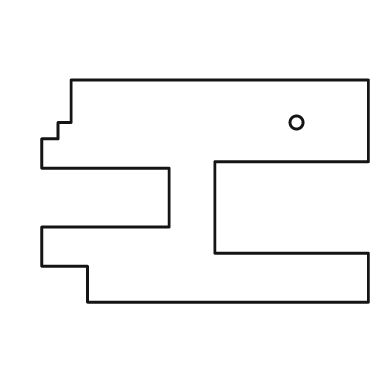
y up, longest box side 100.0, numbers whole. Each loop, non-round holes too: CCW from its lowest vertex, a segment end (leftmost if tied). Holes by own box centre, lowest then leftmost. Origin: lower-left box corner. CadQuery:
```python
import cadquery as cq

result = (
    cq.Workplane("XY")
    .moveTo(14.0, 0.0)
    .lineTo(100.0, 0.0)
    .lineTo(100.0, 15.0)
    .lineTo(53.0, 15.0)
    .lineTo(53.0, 43.0)
    .lineTo(100.0, 43.0)
    .lineTo(100.0, 68.0)
    .lineTo(9.0, 68.0)
    .lineTo(9.0, 55.0)
    .lineTo(5.0, 55.0)
    .lineTo(5.0, 50.0)
    .lineTo(0.0, 50.0)
    .lineTo(0.0, 41.0)
    .lineTo(39.0, 41.0)
    .lineTo(39.0, 23.0)
    .lineTo(0.0, 23.0)
    .lineTo(0.0, 11.0)
    .lineTo(14.0, 11.0)
    .close()
    .moveTo(78.0, 55.0)
    .circle(2.0)
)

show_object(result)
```